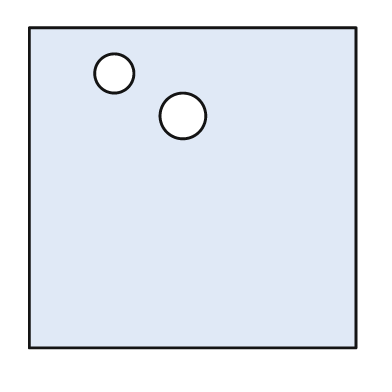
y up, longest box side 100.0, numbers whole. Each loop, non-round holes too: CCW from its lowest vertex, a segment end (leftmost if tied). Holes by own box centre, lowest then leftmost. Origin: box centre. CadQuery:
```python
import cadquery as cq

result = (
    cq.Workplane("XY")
    .moveTo(-50.0, -49.0)
    .lineTo(50.0, -49.0)
    .lineTo(50.0, 49.0)
    .lineTo(-50.0, 49.0)
    .close()
    .moveTo(-3.0, 22.0)
    .circle(7.0)
    .moveTo(-24.0, 35.0)
    .circle(6.0)
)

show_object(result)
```